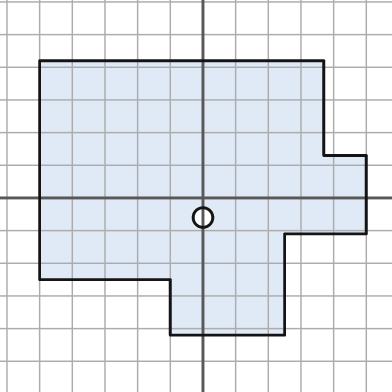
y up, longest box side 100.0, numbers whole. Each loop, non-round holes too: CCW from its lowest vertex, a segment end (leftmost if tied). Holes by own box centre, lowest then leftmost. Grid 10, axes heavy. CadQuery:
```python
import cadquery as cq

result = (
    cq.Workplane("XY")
    .moveTo(-10.0, -42.0)
    .lineTo(25.0, -42.0)
    .lineTo(25.0, -11.0)
    .lineTo(50.0, -11.0)
    .lineTo(50.0, 13.0)
    .lineTo(37.0, 13.0)
    .lineTo(37.0, 42.0)
    .lineTo(-50.0, 42.0)
    .lineTo(-50.0, -25.0)
    .lineTo(-10.0, -25.0)
    .close()
    .moveTo(0.0, -6.0)
    .circle(3.0)
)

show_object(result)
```